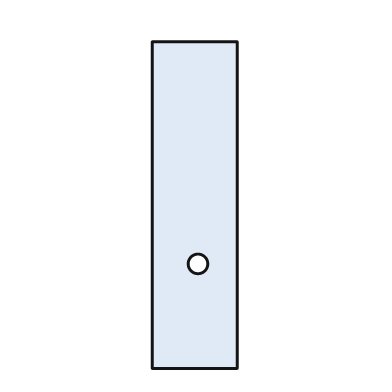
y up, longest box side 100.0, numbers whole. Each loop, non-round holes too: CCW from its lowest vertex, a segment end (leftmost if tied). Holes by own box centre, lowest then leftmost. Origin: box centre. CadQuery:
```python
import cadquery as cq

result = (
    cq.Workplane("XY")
    .moveTo(-13.0, -50.0)
    .lineTo(13.0, -50.0)
    .lineTo(13.0, 50.0)
    .lineTo(-13.0, 50.0)
    .close()
    .moveTo(1.0, -18.0)
    .circle(3.0)
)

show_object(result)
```